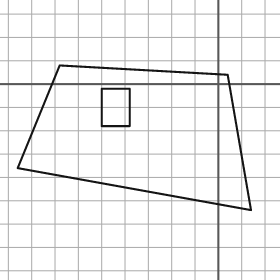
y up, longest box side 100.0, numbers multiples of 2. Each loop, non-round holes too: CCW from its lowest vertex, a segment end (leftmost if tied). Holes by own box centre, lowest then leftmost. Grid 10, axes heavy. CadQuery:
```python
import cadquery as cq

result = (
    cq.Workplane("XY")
    .moveTo(14.0, -54.0)
    .lineTo(4.0, 4.0)
    .lineTo(-68.0, 8.0)
    .lineTo(-86.0, -36.0)
    .close()
    .moveTo(-50.0, -18.0)
    .lineTo(-38.0, -18.0)
    .lineTo(-38.0, -2.0)
    .lineTo(-50.0, -2.0)
    .close()
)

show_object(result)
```